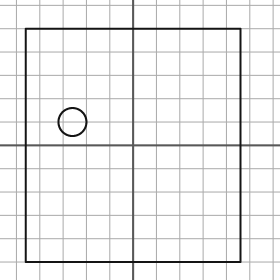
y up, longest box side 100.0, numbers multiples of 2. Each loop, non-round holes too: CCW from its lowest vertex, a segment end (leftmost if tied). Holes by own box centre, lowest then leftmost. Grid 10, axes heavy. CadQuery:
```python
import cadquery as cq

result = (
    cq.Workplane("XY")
    .moveTo(-46.0, -50.0)
    .lineTo(46.0, -50.0)
    .lineTo(46.0, 50.0)
    .lineTo(-46.0, 50.0)
    .close()
    .moveTo(-26.0, 10.0)
    .circle(6.0)
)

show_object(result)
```